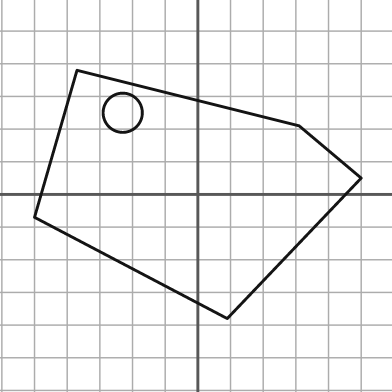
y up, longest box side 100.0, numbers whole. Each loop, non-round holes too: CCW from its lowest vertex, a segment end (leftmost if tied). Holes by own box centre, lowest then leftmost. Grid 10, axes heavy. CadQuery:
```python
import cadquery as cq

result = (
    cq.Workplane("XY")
    .moveTo(9.0, -38.0)
    .lineTo(50.0, 5.0)
    .lineTo(31.0, 21.0)
    .lineTo(-37.0, 38.0)
    .lineTo(-50.0, -7.0)
    .close()
    .moveTo(-23.0, 25.0)
    .circle(6.0)
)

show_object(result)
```